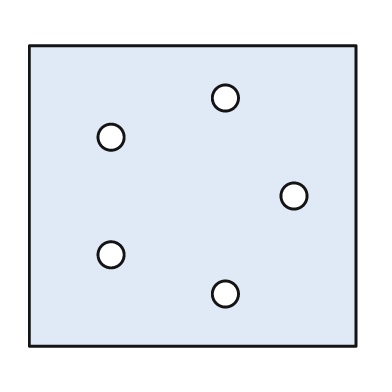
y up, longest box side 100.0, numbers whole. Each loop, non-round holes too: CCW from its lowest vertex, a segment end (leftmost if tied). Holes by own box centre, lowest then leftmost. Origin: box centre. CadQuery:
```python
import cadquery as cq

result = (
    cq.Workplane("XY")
    .moveTo(-50.0, -46.0)
    .lineTo(50.0, -46.0)
    .lineTo(50.0, 46.0)
    .lineTo(-50.0, 46.0)
    .close()
    .moveTo(10.0, -30.0)
    .circle(4.0)
    .moveTo(-25.0, -18.0)
    .circle(4.0)
    .moveTo(31.0, 0.0)
    .circle(4.0)
    .moveTo(-25.0, 18.0)
    .circle(4.0)
    .moveTo(10.0, 30.0)
    .circle(4.0)
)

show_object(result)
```